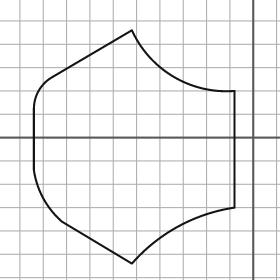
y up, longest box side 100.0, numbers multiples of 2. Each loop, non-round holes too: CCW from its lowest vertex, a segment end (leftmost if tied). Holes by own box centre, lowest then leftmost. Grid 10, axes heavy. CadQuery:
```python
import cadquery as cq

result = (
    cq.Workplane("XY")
    .moveTo(-52.0, -54.0)
    .threePointArc((-32.0, -38.0), (-8.0, -30.0))
    .lineTo(-8.0, 20.0)
    .threePointArc((-34.0, 26.0), (-52.0, 46.0))
    .lineTo(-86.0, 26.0)
    .threePointArc((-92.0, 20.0), (-94.0, 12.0))
    .lineTo(-94.0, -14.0)
    .threePointArc((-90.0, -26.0), (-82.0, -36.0))
    .close()
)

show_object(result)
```